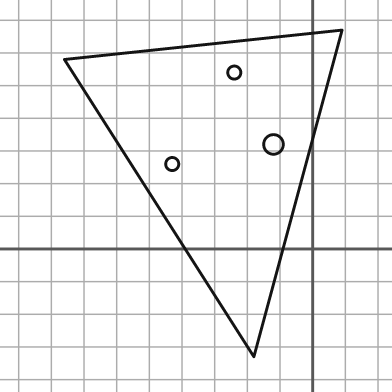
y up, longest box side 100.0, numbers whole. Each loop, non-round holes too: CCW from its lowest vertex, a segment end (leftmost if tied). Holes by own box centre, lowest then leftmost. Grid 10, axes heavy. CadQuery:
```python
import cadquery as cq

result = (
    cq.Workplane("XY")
    .moveTo(-18.0, -33.0)
    .lineTo(9.0, 67.0)
    .lineTo(-76.0, 58.0)
    .close()
    .moveTo(-43.0, 26.0)
    .circle(2.0)
    .moveTo(-12.0, 32.0)
    .circle(3.0)
    .moveTo(-24.0, 54.0)
    .circle(2.0)
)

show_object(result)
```